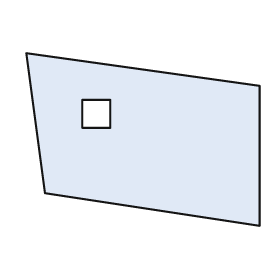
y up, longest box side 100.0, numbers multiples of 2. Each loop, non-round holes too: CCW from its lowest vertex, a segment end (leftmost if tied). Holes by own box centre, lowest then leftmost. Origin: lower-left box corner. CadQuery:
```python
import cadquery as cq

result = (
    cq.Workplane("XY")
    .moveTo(100.0, 0.0)
    .lineTo(100.0, 60.0)
    .lineTo(0.0, 74.0)
    .lineTo(8.0, 14.0)
    .close()
    .moveTo(24.0, 42.0)
    .lineTo(36.0, 42.0)
    .lineTo(36.0, 54.0)
    .lineTo(24.0, 54.0)
    .close()
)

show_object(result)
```